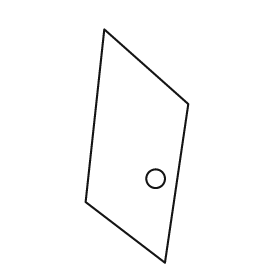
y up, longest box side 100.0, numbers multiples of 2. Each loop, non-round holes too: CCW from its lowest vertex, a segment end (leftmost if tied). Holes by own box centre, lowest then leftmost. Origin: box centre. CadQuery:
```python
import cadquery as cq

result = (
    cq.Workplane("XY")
    .moveTo(12.0, -50.0)
    .lineTo(22.0, 18.0)
    .lineTo(-14.0, 50.0)
    .lineTo(-22.0, -24.0)
    .close()
    .moveTo(8.0, -14.0)
    .circle(4.0)
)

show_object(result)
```